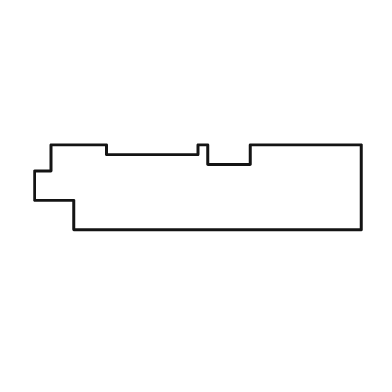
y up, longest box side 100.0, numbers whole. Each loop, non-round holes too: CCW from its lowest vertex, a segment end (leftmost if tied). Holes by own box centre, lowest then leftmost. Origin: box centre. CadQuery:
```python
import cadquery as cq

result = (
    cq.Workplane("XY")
    .moveTo(-38.0, -13.0)
    .lineTo(50.0, -13.0)
    .lineTo(50.0, 13.0)
    .lineTo(16.0, 13.0)
    .lineTo(16.0, 7.0)
    .lineTo(3.0, 7.0)
    .lineTo(3.0, 13.0)
    .lineTo(0.0, 13.0)
    .lineTo(0.0, 10.0)
    .lineTo(-28.0, 10.0)
    .lineTo(-28.0, 13.0)
    .lineTo(-45.0, 13.0)
    .lineTo(-45.0, 5.0)
    .lineTo(-50.0, 5.0)
    .lineTo(-50.0, -4.0)
    .lineTo(-38.0, -4.0)
    .close()
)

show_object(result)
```